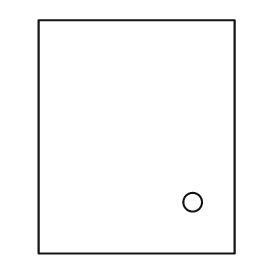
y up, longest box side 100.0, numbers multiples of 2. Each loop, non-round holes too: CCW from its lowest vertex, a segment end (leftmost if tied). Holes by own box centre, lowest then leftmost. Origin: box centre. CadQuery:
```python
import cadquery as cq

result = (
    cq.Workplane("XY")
    .moveTo(-42.0, -50.0)
    .lineTo(42.0, -50.0)
    .lineTo(42.0, 50.0)
    .lineTo(-42.0, 50.0)
    .close()
    .moveTo(24.0, -28.0)
    .circle(4.0)
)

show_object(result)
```